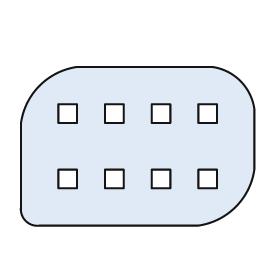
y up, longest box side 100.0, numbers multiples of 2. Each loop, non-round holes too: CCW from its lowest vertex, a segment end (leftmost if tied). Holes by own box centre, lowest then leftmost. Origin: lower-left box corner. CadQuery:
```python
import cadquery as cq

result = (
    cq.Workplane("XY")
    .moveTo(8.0, 0.0)
    .lineTo(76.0, 0.0)
    .threePointArc((92.0, 8.0), (100.0, 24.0))
    .lineTo(100.0, 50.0)
    .threePointArc((94.0, 62.0), (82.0, 68.0))
    .lineTo(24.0, 68.0)
    .threePointArc((8.0, 60.0), (0.0, 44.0))
    .lineTo(0.0, 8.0)
    .threePointArc((2.0, 2.0), (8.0, 0.0))
    .close()
    .moveTo(16.0, 16.0)
    .lineTo(24.0, 16.0)
    .lineTo(24.0, 24.0)
    .lineTo(16.0, 24.0)
    .close()
    .moveTo(36.0, 16.0)
    .lineTo(44.0, 16.0)
    .lineTo(44.0, 24.0)
    .lineTo(36.0, 24.0)
    .close()
    .moveTo(56.0, 16.0)
    .lineTo(64.0, 16.0)
    .lineTo(64.0, 24.0)
    .lineTo(56.0, 24.0)
    .close()
    .moveTo(76.0, 16.0)
    .lineTo(84.0, 16.0)
    .lineTo(84.0, 24.0)
    .lineTo(76.0, 24.0)
    .close()
    .moveTo(16.0, 44.0)
    .lineTo(24.0, 44.0)
    .lineTo(24.0, 52.0)
    .lineTo(16.0, 52.0)
    .close()
    .moveTo(36.0, 44.0)
    .lineTo(44.0, 44.0)
    .lineTo(44.0, 52.0)
    .lineTo(36.0, 52.0)
    .close()
    .moveTo(56.0, 44.0)
    .lineTo(64.0, 44.0)
    .lineTo(64.0, 52.0)
    .lineTo(56.0, 52.0)
    .close()
    .moveTo(76.0, 44.0)
    .lineTo(84.0, 44.0)
    .lineTo(84.0, 52.0)
    .lineTo(76.0, 52.0)
    .close()
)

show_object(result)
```